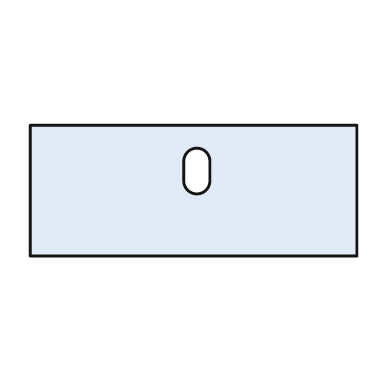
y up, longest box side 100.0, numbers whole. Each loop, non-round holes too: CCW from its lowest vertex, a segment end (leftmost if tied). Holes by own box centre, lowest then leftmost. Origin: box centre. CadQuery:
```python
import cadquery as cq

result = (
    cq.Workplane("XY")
    .moveTo(-50.0, -20.0)
    .lineTo(50.0, -20.0)
    .lineTo(50.0, 20.0)
    .lineTo(-50.0, 20.0)
    .close()
    .moveTo(-3.0, 3.0)
    .threePointArc((1.0, -1.0), (5.0, 3.0))
    .lineTo(5.0, 9.0)
    .threePointArc((1.0, 13.0), (-3.0, 9.0))
    .close()
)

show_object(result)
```